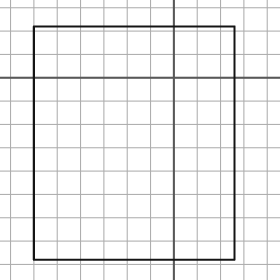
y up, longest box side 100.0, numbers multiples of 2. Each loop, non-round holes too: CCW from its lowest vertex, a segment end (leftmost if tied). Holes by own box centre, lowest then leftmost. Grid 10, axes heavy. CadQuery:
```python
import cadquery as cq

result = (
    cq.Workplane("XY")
    .moveTo(-60.0, -78.0)
    .lineTo(26.0, -78.0)
    .lineTo(26.0, 22.0)
    .lineTo(-60.0, 22.0)
    .close()
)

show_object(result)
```